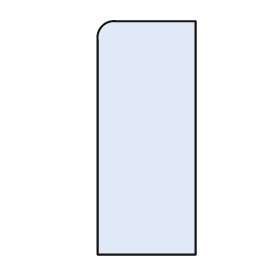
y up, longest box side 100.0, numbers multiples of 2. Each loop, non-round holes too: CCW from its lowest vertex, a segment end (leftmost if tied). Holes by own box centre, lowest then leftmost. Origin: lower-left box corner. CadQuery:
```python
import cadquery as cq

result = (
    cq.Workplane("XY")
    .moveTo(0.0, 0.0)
    .lineTo(42.0, 0.0)
    .lineTo(42.0, 100.0)
    .lineTo(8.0, 100.0)
    .threePointArc((2.0, 98.0), (0.0, 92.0))
    .close()
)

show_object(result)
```